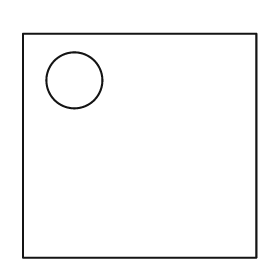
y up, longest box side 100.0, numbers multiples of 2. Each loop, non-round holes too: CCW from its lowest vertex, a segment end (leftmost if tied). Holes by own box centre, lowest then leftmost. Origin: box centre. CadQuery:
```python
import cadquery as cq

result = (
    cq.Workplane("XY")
    .moveTo(-50.0, -48.0)
    .lineTo(50.0, -48.0)
    .lineTo(50.0, 48.0)
    .lineTo(-50.0, 48.0)
    .close()
    .moveTo(-28.0, 28.0)
    .circle(12.0)
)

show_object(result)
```